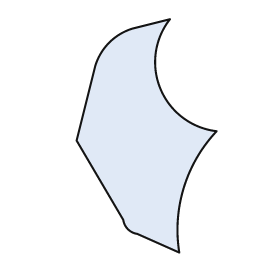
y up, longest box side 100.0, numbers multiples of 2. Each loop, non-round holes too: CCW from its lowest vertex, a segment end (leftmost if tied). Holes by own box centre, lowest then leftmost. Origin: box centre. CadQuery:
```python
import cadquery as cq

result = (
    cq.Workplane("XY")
    .moveTo(14.0, -50.0)
    .threePointArc((16.0, -22.0), (30.0, 2.0))
    .threePointArc((6.0, 20.0), (10.0, 50.0))
    .lineTo(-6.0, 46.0)
    .threePointArc((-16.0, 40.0), (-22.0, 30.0))
    .lineTo(-30.0, -2.0)
    .lineTo(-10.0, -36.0)
    .threePointArc((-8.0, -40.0), (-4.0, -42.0))
    .close()
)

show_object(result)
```